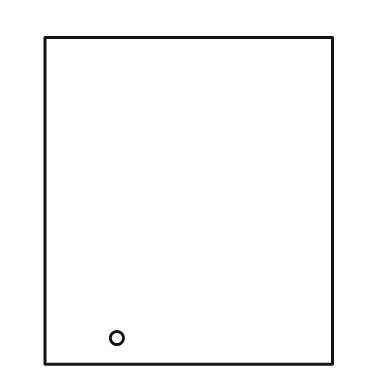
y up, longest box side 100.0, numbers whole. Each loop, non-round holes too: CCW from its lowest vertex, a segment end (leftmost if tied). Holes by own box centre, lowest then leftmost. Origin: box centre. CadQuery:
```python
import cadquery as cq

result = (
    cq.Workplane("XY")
    .moveTo(-44.0, -50.0)
    .lineTo(44.0, -50.0)
    .lineTo(44.0, 50.0)
    .lineTo(-44.0, 50.0)
    .close()
    .moveTo(-22.0, -42.0)
    .circle(2.0)
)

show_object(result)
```